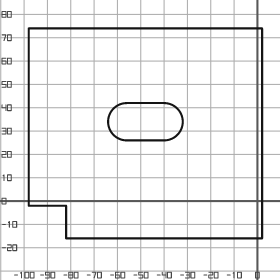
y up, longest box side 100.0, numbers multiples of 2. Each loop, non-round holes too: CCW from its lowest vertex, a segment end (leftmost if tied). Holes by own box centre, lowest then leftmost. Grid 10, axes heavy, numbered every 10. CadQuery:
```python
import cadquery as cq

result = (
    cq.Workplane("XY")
    .moveTo(-82.0, -16.0)
    .lineTo(2.0, -16.0)
    .lineTo(2.0, 74.0)
    .lineTo(-98.0, 74.0)
    .lineTo(-98.0, -2.0)
    .lineTo(-82.0, -2.0)
    .close()
    .moveTo(-56.0, 26.0)
    .lineTo(-40.0, 26.0)
    .threePointArc((-32.0, 34.0), (-40.0, 42.0))
    .lineTo(-56.0, 42.0)
    .threePointArc((-64.0, 34.0), (-56.0, 26.0))
    .close()
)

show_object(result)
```